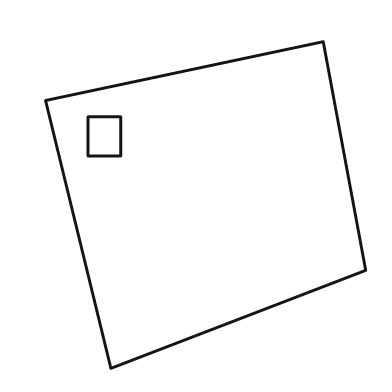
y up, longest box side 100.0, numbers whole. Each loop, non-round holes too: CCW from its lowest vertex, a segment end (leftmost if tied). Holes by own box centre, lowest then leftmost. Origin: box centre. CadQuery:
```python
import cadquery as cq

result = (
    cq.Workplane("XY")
    .moveTo(-29.0, -50.0)
    .lineTo(49.0, -20.0)
    .lineTo(36.0, 50.0)
    .lineTo(-49.0, 32.0)
    .close()
    .moveTo(-36.0, 15.0)
    .lineTo(-26.0, 15.0)
    .lineTo(-26.0, 27.0)
    .lineTo(-36.0, 27.0)
    .close()
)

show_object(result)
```